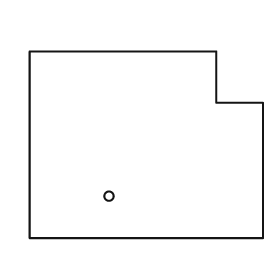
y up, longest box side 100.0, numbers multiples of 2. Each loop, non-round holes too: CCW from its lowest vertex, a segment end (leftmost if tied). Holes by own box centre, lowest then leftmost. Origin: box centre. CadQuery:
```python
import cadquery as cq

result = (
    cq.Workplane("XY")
    .moveTo(-50.0, -40.0)
    .lineTo(50.0, -40.0)
    .lineTo(50.0, 18.0)
    .lineTo(30.0, 18.0)
    .lineTo(30.0, 40.0)
    .lineTo(-50.0, 40.0)
    .close()
    .moveTo(-16.0, -22.0)
    .circle(2.0)
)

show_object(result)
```